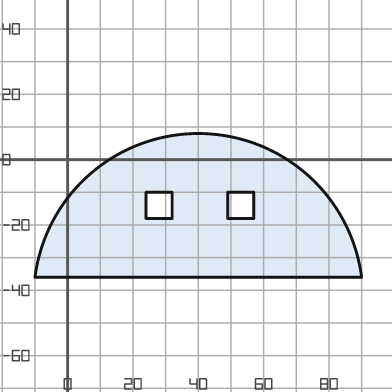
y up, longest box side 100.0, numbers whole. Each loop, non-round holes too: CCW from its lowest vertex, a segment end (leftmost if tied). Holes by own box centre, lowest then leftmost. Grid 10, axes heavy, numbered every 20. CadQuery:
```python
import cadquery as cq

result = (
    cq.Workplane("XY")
    .moveTo(-10.0, -36.0)
    .lineTo(90.0, -36.0)
    .threePointArc((40.0, 8.0), (-10.0, -36.0))
    .close()
    .moveTo(24.0, -18.0)
    .lineTo(32.0, -18.0)
    .lineTo(32.0, -10.0)
    .lineTo(24.0, -10.0)
    .close()
    .moveTo(49.0, -18.0)
    .lineTo(57.0, -18.0)
    .lineTo(57.0, -10.0)
    .lineTo(49.0, -10.0)
    .close()
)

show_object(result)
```